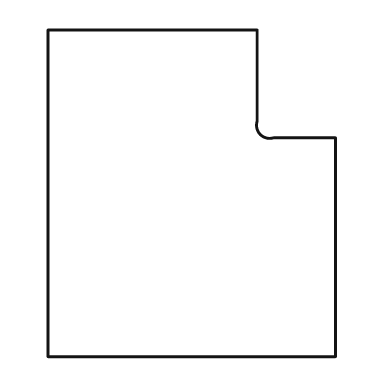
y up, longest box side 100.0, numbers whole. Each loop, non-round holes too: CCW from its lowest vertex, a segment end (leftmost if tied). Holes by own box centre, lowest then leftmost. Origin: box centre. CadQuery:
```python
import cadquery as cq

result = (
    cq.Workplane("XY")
    .moveTo(-44.0, -50.0)
    .lineTo(44.0, -50.0)
    .lineTo(44.0, 17.0)
    .lineTo(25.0, 17.0)
    .threePointArc((21.0, 18.0), (20.0, 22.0))
    .lineTo(20.0, 50.0)
    .lineTo(-44.0, 50.0)
    .close()
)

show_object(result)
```